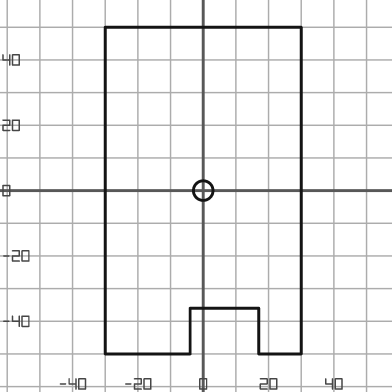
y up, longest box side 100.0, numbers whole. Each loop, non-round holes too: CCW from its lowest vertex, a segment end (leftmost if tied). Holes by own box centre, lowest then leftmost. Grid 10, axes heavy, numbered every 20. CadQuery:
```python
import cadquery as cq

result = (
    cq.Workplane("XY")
    .moveTo(-30.0, -50.0)
    .lineTo(-4.0, -50.0)
    .lineTo(-4.0, -36.0)
    .lineTo(17.0, -36.0)
    .lineTo(17.0, -50.0)
    .lineTo(30.0, -50.0)
    .lineTo(30.0, 50.0)
    .lineTo(-30.0, 50.0)
    .close()
    .moveTo(0.0, 0.0)
    .circle(3.0)
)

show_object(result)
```